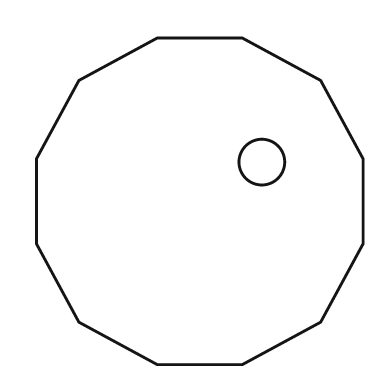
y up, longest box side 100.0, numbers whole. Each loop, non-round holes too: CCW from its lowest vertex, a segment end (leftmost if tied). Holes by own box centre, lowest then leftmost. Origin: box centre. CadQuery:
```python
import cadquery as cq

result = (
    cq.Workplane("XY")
    .moveTo(-13.0, -50.0)
    .lineTo(13.0, -50.0)
    .lineTo(37.0, -37.0)
    .lineTo(50.0, -13.0)
    .lineTo(50.0, 13.0)
    .lineTo(37.0, 37.0)
    .lineTo(13.0, 50.0)
    .lineTo(-13.0, 50.0)
    .lineTo(-37.0, 37.0)
    .lineTo(-50.0, 13.0)
    .lineTo(-50.0, -13.0)
    .lineTo(-37.0, -37.0)
    .close()
    .moveTo(19.0, 12.0)
    .circle(7.0)
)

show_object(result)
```